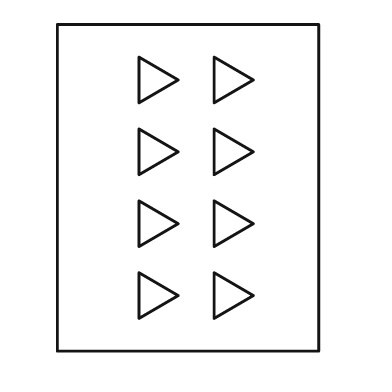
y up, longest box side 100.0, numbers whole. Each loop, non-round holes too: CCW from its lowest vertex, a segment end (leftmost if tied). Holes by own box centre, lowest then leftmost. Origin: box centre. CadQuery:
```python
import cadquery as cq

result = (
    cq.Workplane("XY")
    .moveTo(-40.0, -50.0)
    .lineTo(40.0, -50.0)
    .lineTo(40.0, 50.0)
    .lineTo(-40.0, 50.0)
    .close()
    .moveTo(-15.0, -40.0)
    .lineTo(-3.0, -33.0)
    .lineTo(-15.0, -26.0)
    .close()
    .moveTo(8.0, -40.0)
    .lineTo(20.0, -33.0)
    .lineTo(8.0, -26.0)
    .close()
    .moveTo(-15.0, -18.0)
    .lineTo(-3.0, -11.0)
    .lineTo(-15.0, -4.0)
    .close()
    .moveTo(8.0, -18.0)
    .lineTo(20.0, -11.0)
    .lineTo(8.0, -4.0)
    .close()
    .moveTo(-15.0, 4.0)
    .lineTo(-3.0, 11.0)
    .lineTo(-15.0, 18.0)
    .close()
    .moveTo(8.0, 4.0)
    .lineTo(20.0, 11.0)
    .lineTo(8.0, 18.0)
    .close()
    .moveTo(-15.0, 26.0)
    .lineTo(-3.0, 33.0)
    .lineTo(-15.0, 40.0)
    .close()
    .moveTo(8.0, 26.0)
    .lineTo(20.0, 33.0)
    .lineTo(8.0, 40.0)
    .close()
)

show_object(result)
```